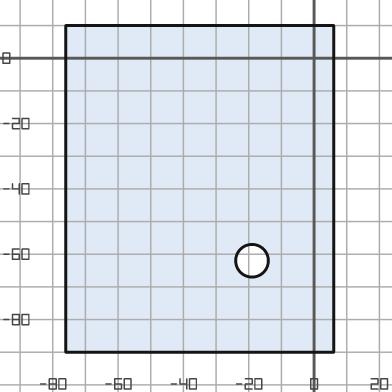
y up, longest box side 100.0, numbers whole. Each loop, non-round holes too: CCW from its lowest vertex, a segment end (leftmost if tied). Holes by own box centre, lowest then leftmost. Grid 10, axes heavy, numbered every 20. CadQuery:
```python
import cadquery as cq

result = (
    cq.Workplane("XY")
    .moveTo(-76.0, -90.0)
    .lineTo(6.0, -90.0)
    .lineTo(6.0, 10.0)
    .lineTo(-76.0, 10.0)
    .close()
    .moveTo(-19.0, -62.0)
    .circle(5.0)
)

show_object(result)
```